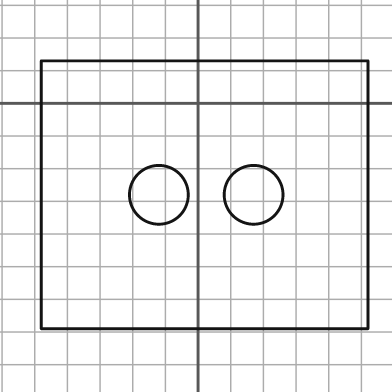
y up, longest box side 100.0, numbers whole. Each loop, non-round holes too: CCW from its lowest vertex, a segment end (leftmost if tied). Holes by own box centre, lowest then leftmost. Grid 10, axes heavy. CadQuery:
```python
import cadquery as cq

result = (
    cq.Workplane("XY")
    .moveTo(-48.0, -69.0)
    .lineTo(52.0, -69.0)
    .lineTo(52.0, 13.0)
    .lineTo(-48.0, 13.0)
    .close()
    .moveTo(-12.0, -28.0)
    .circle(9.0)
    .moveTo(17.0, -28.0)
    .circle(9.0)
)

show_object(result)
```